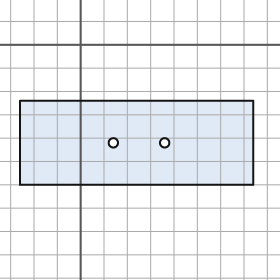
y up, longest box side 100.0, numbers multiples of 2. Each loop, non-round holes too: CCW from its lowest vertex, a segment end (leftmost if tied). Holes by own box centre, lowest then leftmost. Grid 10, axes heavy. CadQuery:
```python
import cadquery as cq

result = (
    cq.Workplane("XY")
    .moveTo(-26.0, -60.0)
    .lineTo(74.0, -60.0)
    .lineTo(74.0, -24.0)
    .lineTo(-26.0, -24.0)
    .close()
    .moveTo(14.0, -42.0)
    .circle(2.0)
    .moveTo(36.0, -42.0)
    .circle(2.0)
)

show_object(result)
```